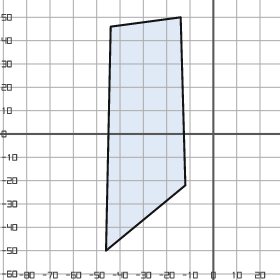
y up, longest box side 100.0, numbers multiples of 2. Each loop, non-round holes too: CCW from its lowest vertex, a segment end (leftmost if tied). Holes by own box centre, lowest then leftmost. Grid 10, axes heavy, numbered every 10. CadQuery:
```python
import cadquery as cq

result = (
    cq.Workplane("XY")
    .moveTo(-46.0, -50.0)
    .lineTo(-12.0, -22.0)
    .lineTo(-14.0, 50.0)
    .lineTo(-44.0, 46.0)
    .close()
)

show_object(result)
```